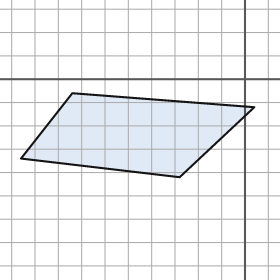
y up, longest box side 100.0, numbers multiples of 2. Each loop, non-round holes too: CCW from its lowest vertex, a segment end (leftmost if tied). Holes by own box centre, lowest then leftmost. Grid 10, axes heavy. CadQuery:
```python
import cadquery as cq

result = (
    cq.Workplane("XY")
    .moveTo(-28.0, -42.0)
    .lineTo(4.0, -12.0)
    .lineTo(-74.0, -6.0)
    .lineTo(-96.0, -34.0)
    .close()
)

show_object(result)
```